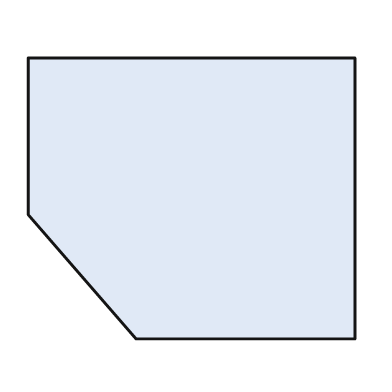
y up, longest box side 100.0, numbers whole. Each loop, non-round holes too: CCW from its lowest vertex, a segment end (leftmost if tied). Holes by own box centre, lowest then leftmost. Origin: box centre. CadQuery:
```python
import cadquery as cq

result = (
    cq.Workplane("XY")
    .moveTo(-17.0, -43.0)
    .lineTo(50.0, -43.0)
    .lineTo(50.0, 43.0)
    .lineTo(-50.0, 43.0)
    .lineTo(-50.0, -5.0)
    .close()
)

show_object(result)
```